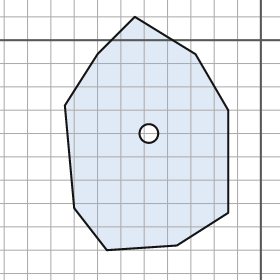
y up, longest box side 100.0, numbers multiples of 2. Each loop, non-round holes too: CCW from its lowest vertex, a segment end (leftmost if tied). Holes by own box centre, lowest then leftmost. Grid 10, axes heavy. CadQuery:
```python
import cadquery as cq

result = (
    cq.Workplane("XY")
    .moveTo(-66.0, -90.0)
    .lineTo(-36.0, -88.0)
    .lineTo(-14.0, -74.0)
    .lineTo(-14.0, -30.0)
    .lineTo(-28.0, -6.0)
    .lineTo(-54.0, 10.0)
    .lineTo(-70.0, -6.0)
    .lineTo(-84.0, -28.0)
    .lineTo(-80.0, -72.0)
    .close()
    .moveTo(-48.0, -40.0)
    .circle(4.0)
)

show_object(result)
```